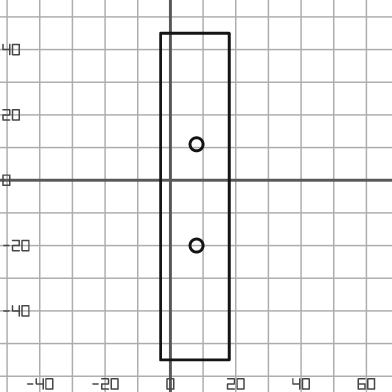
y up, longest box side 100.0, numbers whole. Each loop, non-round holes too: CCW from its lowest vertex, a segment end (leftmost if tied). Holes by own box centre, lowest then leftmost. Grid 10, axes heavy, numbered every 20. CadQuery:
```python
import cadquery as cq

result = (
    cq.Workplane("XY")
    .moveTo(-3.0, -55.0)
    .lineTo(18.0, -55.0)
    .lineTo(18.0, 45.0)
    .lineTo(-3.0, 45.0)
    .close()
    .moveTo(8.0, -20.0)
    .circle(2.0)
    .moveTo(8.0, 11.0)
    .circle(2.0)
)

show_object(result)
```